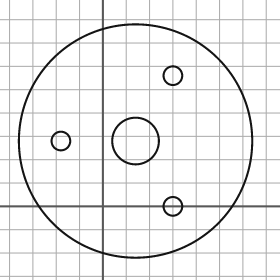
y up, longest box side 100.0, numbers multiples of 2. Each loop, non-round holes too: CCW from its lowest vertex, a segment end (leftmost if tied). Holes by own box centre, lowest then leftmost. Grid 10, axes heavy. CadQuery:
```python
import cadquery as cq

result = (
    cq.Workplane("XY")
    .moveTo(14.0, 28.0)
    .circle(50.0)
    .moveTo(30.0, 0.0)
    .circle(4.0)
    .moveTo(-18.0, 28.0)
    .circle(4.0)
    .moveTo(14.0, 28.0)
    .circle(10.0)
    .moveTo(30.0, 56.0)
    .circle(4.0)
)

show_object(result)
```